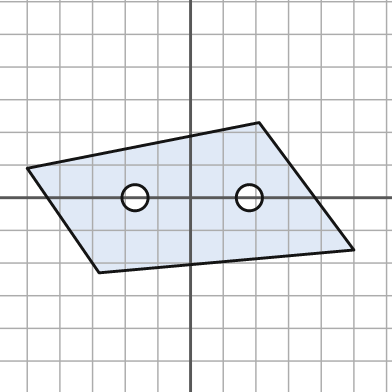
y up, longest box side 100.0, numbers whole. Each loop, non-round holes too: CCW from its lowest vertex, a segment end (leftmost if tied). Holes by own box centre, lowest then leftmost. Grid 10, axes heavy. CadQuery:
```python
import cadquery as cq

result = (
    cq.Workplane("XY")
    .moveTo(-28.0, -23.0)
    .lineTo(50.0, -16.0)
    .lineTo(21.0, 23.0)
    .lineTo(-50.0, 9.0)
    .close()
    .moveTo(-17.0, 0.0)
    .circle(4.0)
    .moveTo(18.0, 0.0)
    .circle(4.0)
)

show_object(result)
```